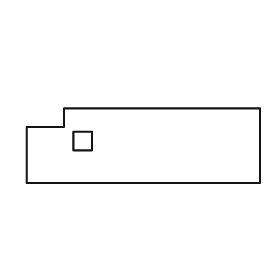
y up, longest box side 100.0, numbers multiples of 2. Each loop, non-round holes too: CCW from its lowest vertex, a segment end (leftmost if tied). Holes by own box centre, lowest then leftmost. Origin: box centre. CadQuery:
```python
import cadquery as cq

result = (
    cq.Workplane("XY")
    .moveTo(-50.0, -16.0)
    .lineTo(50.0, -16.0)
    .lineTo(50.0, 16.0)
    .lineTo(-34.0, 16.0)
    .lineTo(-34.0, 8.0)
    .lineTo(-50.0, 8.0)
    .close()
    .moveTo(-30.0, -2.0)
    .lineTo(-22.0, -2.0)
    .lineTo(-22.0, 6.0)
    .lineTo(-30.0, 6.0)
    .close()
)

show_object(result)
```